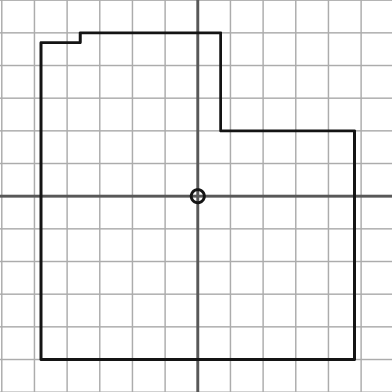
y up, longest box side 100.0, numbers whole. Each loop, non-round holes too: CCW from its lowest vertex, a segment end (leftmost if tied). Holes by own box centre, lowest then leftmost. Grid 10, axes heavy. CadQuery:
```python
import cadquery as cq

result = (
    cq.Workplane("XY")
    .moveTo(-48.0, -50.0)
    .lineTo(48.0, -50.0)
    .lineTo(48.0, 20.0)
    .lineTo(7.0, 20.0)
    .lineTo(7.0, 50.0)
    .lineTo(-36.0, 50.0)
    .lineTo(-36.0, 47.0)
    .lineTo(-48.0, 47.0)
    .close()
    .moveTo(0.0, 0.0)
    .circle(2.0)
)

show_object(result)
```